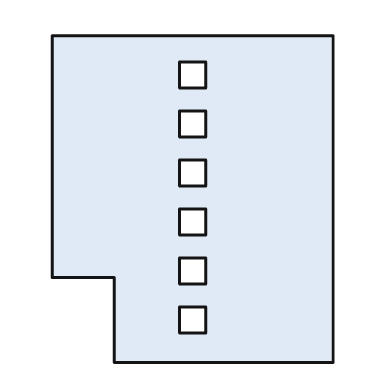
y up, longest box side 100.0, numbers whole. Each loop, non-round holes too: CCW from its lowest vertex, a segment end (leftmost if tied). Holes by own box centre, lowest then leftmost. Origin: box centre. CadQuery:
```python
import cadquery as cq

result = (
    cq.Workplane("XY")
    .moveTo(-24.0, -50.0)
    .lineTo(43.0, -50.0)
    .lineTo(43.0, 50.0)
    .lineTo(-43.0, 50.0)
    .lineTo(-43.0, -24.0)
    .lineTo(-24.0, -24.0)
    .close()
    .moveTo(-4.0, -41.0)
    .lineTo(4.0, -41.0)
    .lineTo(4.0, -33.0)
    .lineTo(-4.0, -33.0)
    .close()
    .moveTo(-4.0, -26.0)
    .lineTo(4.0, -26.0)
    .lineTo(4.0, -18.0)
    .lineTo(-4.0, -18.0)
    .close()
    .moveTo(-4.0, -11.0)
    .lineTo(4.0, -11.0)
    .lineTo(4.0, -3.0)
    .lineTo(-4.0, -3.0)
    .close()
    .moveTo(-4.0, 4.0)
    .lineTo(4.0, 4.0)
    .lineTo(4.0, 12.0)
    .lineTo(-4.0, 12.0)
    .close()
    .moveTo(-4.0, 19.0)
    .lineTo(4.0, 19.0)
    .lineTo(4.0, 27.0)
    .lineTo(-4.0, 27.0)
    .close()
    .moveTo(-4.0, 34.0)
    .lineTo(4.0, 34.0)
    .lineTo(4.0, 42.0)
    .lineTo(-4.0, 42.0)
    .close()
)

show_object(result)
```